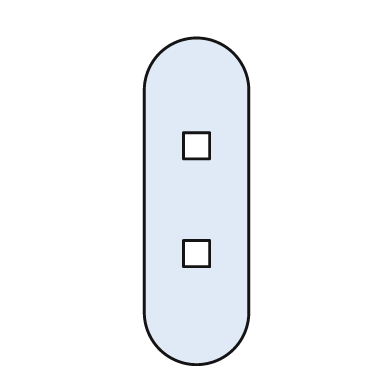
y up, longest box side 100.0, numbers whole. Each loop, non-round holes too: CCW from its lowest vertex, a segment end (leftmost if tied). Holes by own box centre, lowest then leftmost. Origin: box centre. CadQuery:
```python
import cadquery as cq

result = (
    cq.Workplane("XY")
    .moveTo(-16.0, -34.0)
    .threePointArc((0.0, -50.0), (16.0, -34.0))
    .lineTo(16.0, 34.0)
    .threePointArc((0.0, 50.0), (-16.0, 34.0))
    .close()
    .moveTo(-4.0, -20.0)
    .lineTo(4.0, -20.0)
    .lineTo(4.0, -12.0)
    .lineTo(-4.0, -12.0)
    .close()
    .moveTo(-4.0, 13.0)
    .lineTo(4.0, 13.0)
    .lineTo(4.0, 21.0)
    .lineTo(-4.0, 21.0)
    .close()
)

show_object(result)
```